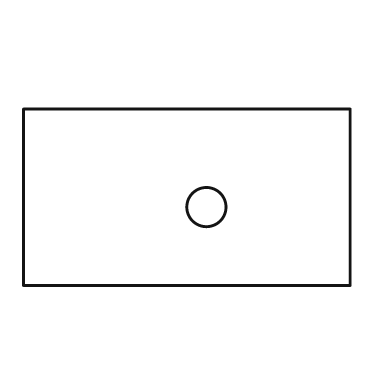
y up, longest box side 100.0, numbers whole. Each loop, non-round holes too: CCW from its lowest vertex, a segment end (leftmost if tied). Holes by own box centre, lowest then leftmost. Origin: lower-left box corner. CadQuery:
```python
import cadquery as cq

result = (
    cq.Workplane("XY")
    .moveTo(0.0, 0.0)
    .lineTo(100.0, 0.0)
    .lineTo(100.0, 54.0)
    .lineTo(0.0, 54.0)
    .close()
    .moveTo(56.0, 24.0)
    .circle(6.0)
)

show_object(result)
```